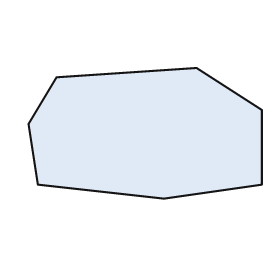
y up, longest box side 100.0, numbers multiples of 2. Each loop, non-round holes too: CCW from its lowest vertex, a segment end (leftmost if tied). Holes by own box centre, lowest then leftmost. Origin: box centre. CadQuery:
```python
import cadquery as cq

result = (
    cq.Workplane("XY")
    .moveTo(8.0, -28.0)
    .lineTo(50.0, -22.0)
    .lineTo(50.0, 10.0)
    .lineTo(22.0, 28.0)
    .lineTo(-38.0, 24.0)
    .lineTo(-50.0, 4.0)
    .lineTo(-46.0, -22.0)
    .close()
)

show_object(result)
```